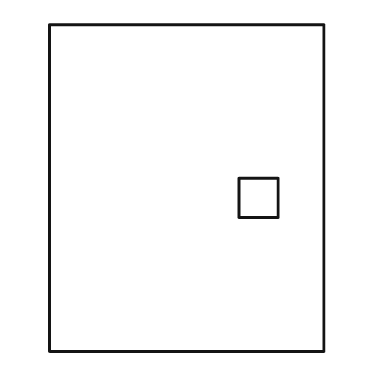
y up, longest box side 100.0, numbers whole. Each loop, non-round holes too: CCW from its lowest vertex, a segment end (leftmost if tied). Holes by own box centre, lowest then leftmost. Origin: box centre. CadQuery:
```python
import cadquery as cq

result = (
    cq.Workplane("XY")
    .moveTo(-42.0, -50.0)
    .lineTo(42.0, -50.0)
    .lineTo(42.0, 50.0)
    .lineTo(-42.0, 50.0)
    .close()
    .moveTo(16.0, -9.0)
    .lineTo(28.0, -9.0)
    .lineTo(28.0, 3.0)
    .lineTo(16.0, 3.0)
    .close()
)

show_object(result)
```